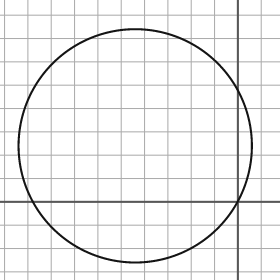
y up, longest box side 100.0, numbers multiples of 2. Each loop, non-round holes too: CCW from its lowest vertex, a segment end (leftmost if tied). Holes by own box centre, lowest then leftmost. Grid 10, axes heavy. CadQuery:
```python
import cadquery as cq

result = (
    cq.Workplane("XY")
    .moveTo(-44.0, 24.0)
    .circle(50.0)
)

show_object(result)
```